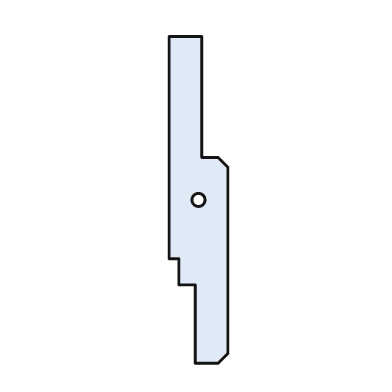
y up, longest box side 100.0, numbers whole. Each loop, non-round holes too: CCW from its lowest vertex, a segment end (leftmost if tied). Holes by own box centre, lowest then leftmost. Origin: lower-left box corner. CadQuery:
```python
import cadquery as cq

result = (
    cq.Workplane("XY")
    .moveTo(8.0, 0.0)
    .lineTo(15.0, 0.0)
    .lineTo(18.0, 3.0)
    .lineTo(18.0, 60.0)
    .lineTo(15.0, 63.0)
    .lineTo(10.0, 63.0)
    .lineTo(10.0, 100.0)
    .lineTo(0.0, 100.0)
    .lineTo(0.0, 32.0)
    .lineTo(3.0, 32.0)
    .lineTo(3.0, 24.0)
    .lineTo(8.0, 24.0)
    .close()
    .moveTo(9.0, 50.0)
    .circle(2.0)
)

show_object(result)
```